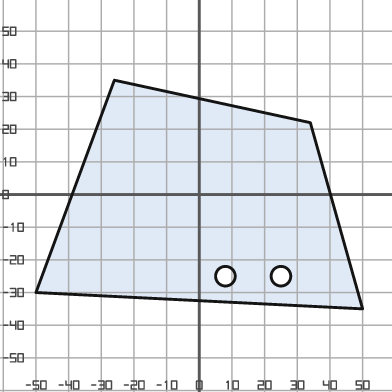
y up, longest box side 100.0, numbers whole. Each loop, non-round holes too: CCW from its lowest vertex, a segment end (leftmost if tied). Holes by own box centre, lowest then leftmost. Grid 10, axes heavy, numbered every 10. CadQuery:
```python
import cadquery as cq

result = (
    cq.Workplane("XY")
    .moveTo(50.0, -35.0)
    .lineTo(34.0, 22.0)
    .lineTo(-26.0, 35.0)
    .lineTo(-50.0, -30.0)
    .close()
    .moveTo(8.0, -25.0)
    .circle(3.0)
    .moveTo(25.0, -25.0)
    .circle(3.0)
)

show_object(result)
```